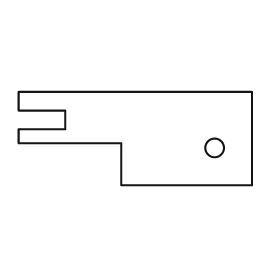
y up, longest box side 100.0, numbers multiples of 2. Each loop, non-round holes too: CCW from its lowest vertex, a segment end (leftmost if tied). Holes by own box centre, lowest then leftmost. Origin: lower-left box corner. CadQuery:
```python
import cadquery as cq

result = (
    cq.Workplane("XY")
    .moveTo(44.0, 0.0)
    .lineTo(100.0, 0.0)
    .lineTo(100.0, 40.0)
    .lineTo(0.0, 40.0)
    .lineTo(0.0, 32.0)
    .lineTo(20.0, 32.0)
    .lineTo(20.0, 24.0)
    .lineTo(0.0, 24.0)
    .lineTo(0.0, 18.0)
    .lineTo(44.0, 18.0)
    .close()
    .moveTo(84.0, 16.0)
    .circle(4.0)
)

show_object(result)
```